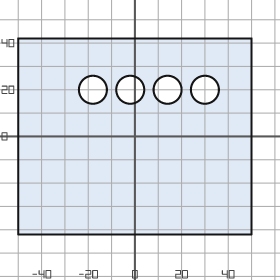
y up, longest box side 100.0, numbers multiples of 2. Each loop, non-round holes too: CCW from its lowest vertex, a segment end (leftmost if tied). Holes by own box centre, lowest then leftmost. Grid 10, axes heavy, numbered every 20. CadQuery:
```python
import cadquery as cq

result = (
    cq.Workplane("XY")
    .moveTo(-50.0, -42.0)
    .lineTo(50.0, -42.0)
    .lineTo(50.0, 42.0)
    .lineTo(-50.0, 42.0)
    .close()
    .moveTo(-18.0, 20.0)
    .circle(6.0)
    .moveTo(-2.0, 20.0)
    .circle(6.0)
    .moveTo(14.0, 20.0)
    .circle(6.0)
    .moveTo(30.0, 20.0)
    .circle(6.0)
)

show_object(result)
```